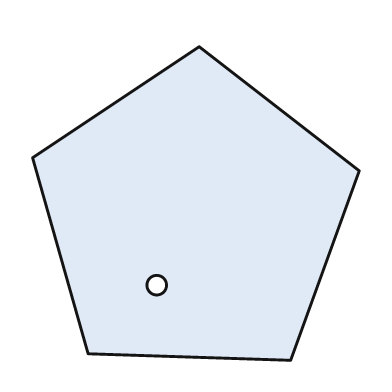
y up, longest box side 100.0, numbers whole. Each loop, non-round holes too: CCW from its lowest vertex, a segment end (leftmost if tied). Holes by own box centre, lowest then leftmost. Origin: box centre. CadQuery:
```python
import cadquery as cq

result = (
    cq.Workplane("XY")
    .moveTo(29.0, -48.0)
    .lineTo(50.0, 10.0)
    .lineTo(1.0, 48.0)
    .lineTo(-50.0, 14.0)
    .lineTo(-33.0, -46.0)
    .close()
    .moveTo(-12.0, -25.0)
    .circle(3.0)
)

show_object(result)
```